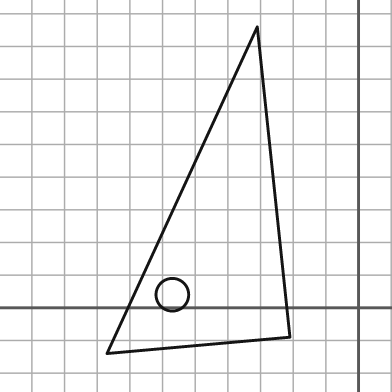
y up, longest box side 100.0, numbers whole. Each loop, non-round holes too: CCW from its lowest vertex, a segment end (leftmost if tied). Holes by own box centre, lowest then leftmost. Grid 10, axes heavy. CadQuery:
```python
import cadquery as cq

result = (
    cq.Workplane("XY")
    .moveTo(-77.0, -14.0)
    .lineTo(-21.0, -9.0)
    .lineTo(-31.0, 86.0)
    .close()
    .moveTo(-57.0, 4.0)
    .circle(5.0)
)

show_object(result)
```